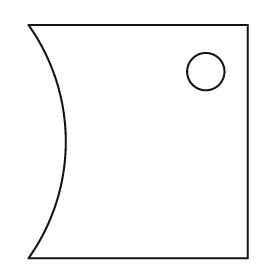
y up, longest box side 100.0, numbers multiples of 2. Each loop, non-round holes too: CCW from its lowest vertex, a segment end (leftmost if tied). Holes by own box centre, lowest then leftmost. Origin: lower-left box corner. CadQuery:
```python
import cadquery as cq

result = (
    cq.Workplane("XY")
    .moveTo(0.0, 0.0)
    .lineTo(94.0, 0.0)
    .lineTo(94.0, 100.0)
    .lineTo(0.0, 100.0)
    .threePointArc((16.0, 50.0), (0.0, 0.0))
    .close()
    .moveTo(76.0, 80.0)
    .circle(8.0)
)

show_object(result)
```